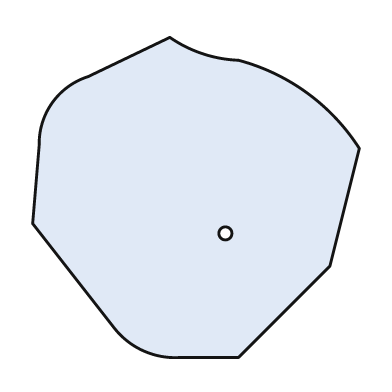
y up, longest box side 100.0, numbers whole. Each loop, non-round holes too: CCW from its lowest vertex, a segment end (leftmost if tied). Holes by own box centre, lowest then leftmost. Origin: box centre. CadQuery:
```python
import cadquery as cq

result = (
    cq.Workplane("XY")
    .moveTo(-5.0, -49.0)
    .lineTo(13.0, -49.0)
    .lineTo(41.0, -21.0)
    .lineTo(50.0, 15.0)
    .threePointArc((34.0, 32.0), (13.0, 42.0))
    .threePointArc((2.0, 44.0), (-8.0, 49.0))
    .lineTo(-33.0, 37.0)
    .threePointArc((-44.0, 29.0), (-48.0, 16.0))
    .lineTo(-50.0, -8.0)
    .lineTo(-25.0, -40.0)
    .threePointArc((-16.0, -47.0), (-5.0, -49.0))
    .close()
    .moveTo(9.0, -11.0)
    .circle(2.0)
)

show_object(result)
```